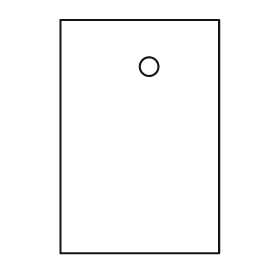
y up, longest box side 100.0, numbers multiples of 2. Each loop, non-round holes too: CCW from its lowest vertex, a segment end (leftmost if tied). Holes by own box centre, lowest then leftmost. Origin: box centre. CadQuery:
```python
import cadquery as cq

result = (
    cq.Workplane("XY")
    .moveTo(-34.0, -50.0)
    .lineTo(34.0, -50.0)
    .lineTo(34.0, 50.0)
    .lineTo(-34.0, 50.0)
    .close()
    .moveTo(4.0, 30.0)
    .circle(4.0)
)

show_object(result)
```